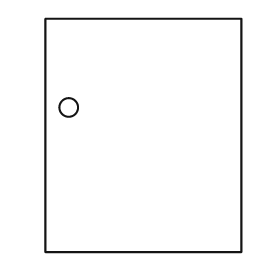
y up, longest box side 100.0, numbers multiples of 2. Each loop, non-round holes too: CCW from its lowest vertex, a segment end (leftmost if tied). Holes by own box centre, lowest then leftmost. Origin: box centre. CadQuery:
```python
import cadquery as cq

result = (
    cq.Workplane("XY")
    .moveTo(-42.0, -50.0)
    .lineTo(42.0, -50.0)
    .lineTo(42.0, 50.0)
    .lineTo(-42.0, 50.0)
    .close()
    .moveTo(-32.0, 12.0)
    .circle(4.0)
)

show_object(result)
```